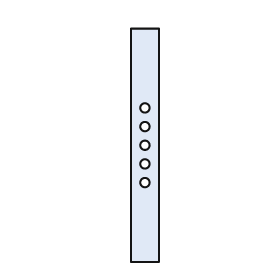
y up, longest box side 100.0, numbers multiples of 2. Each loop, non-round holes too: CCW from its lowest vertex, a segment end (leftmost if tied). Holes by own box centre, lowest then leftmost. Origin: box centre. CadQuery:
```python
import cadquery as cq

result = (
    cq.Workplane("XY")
    .moveTo(-6.0, -50.0)
    .lineTo(6.0, -50.0)
    .lineTo(6.0, 50.0)
    .lineTo(-6.0, 50.0)
    .close()
    .moveTo(0.0, -16.0)
    .circle(2.0)
    .moveTo(0.0, -8.0)
    .circle(2.0)
    .moveTo(0.0, 0.0)
    .circle(2.0)
    .moveTo(0.0, 8.0)
    .circle(2.0)
    .moveTo(0.0, 16.0)
    .circle(2.0)
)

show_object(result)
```